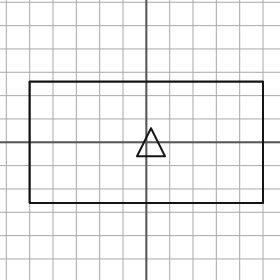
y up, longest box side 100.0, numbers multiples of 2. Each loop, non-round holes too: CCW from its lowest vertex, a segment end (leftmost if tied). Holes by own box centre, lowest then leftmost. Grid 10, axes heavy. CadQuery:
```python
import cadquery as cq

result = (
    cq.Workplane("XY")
    .moveTo(-50.0, -26.0)
    .lineTo(50.0, -26.0)
    .lineTo(50.0, 26.0)
    .lineTo(-50.0, 26.0)
    .close()
    .moveTo(-4.0, -6.0)
    .lineTo(8.0, -6.0)
    .lineTo(2.0, 6.0)
    .close()
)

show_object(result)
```